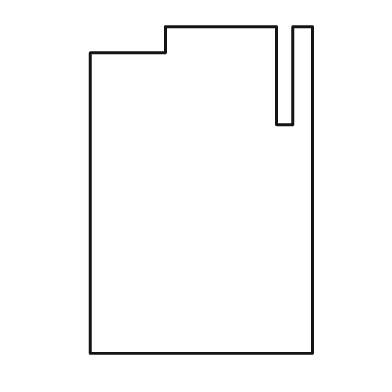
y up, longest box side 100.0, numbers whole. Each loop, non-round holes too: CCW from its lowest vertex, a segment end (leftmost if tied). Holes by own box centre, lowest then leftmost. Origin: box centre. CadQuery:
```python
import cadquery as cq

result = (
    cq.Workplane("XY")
    .moveTo(-34.0, -50.0)
    .lineTo(34.0, -50.0)
    .lineTo(34.0, 50.0)
    .lineTo(28.0, 50.0)
    .lineTo(28.0, 20.0)
    .lineTo(23.0, 20.0)
    .lineTo(23.0, 50.0)
    .lineTo(-11.0, 50.0)
    .lineTo(-11.0, 42.0)
    .lineTo(-34.0, 42.0)
    .close()
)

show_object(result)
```